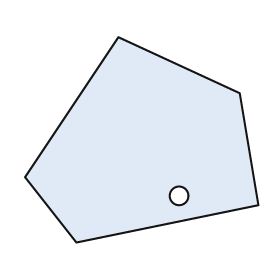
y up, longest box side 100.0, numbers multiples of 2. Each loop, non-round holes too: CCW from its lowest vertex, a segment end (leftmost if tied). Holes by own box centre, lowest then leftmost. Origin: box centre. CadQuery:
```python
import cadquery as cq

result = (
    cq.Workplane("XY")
    .moveTo(-28.0, -44.0)
    .lineTo(50.0, -28.0)
    .lineTo(42.0, 20.0)
    .lineTo(-10.0, 44.0)
    .lineTo(-50.0, -16.0)
    .close()
    .moveTo(16.0, -24.0)
    .circle(4.0)
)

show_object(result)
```